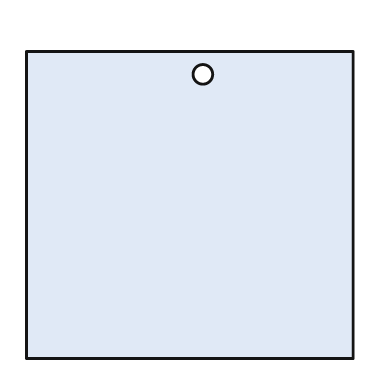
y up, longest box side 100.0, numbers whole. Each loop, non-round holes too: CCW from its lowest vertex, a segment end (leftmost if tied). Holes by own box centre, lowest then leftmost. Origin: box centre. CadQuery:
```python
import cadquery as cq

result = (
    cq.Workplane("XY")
    .moveTo(-50.0, -47.0)
    .lineTo(50.0, -47.0)
    .lineTo(50.0, 47.0)
    .lineTo(-50.0, 47.0)
    .close()
    .moveTo(4.0, 40.0)
    .circle(3.0)
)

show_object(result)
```